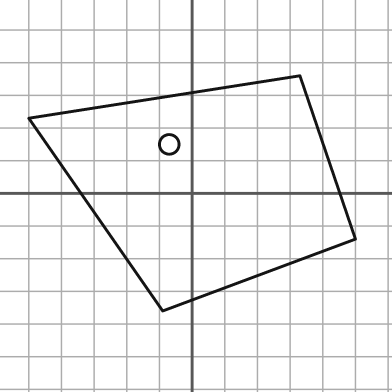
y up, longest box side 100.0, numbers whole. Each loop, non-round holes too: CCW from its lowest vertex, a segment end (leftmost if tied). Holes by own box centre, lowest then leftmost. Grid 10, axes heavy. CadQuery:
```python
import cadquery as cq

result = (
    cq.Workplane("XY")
    .moveTo(-9.0, -36.0)
    .lineTo(50.0, -14.0)
    .lineTo(33.0, 36.0)
    .lineTo(-50.0, 23.0)
    .close()
    .moveTo(-7.0, 15.0)
    .circle(3.0)
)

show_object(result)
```